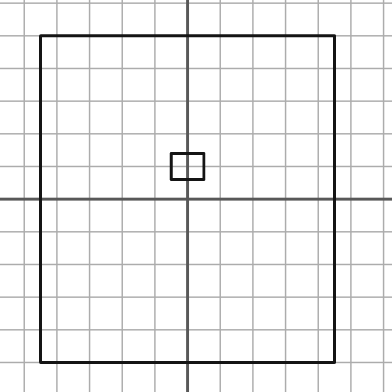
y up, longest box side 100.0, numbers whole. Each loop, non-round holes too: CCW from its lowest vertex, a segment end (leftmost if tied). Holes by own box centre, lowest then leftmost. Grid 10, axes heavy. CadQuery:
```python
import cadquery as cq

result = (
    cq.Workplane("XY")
    .moveTo(-45.0, -50.0)
    .lineTo(45.0, -50.0)
    .lineTo(45.0, 50.0)
    .lineTo(-45.0, 50.0)
    .close()
    .moveTo(-5.0, 6.0)
    .lineTo(5.0, 6.0)
    .lineTo(5.0, 14.0)
    .lineTo(-5.0, 14.0)
    .close()
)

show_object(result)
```